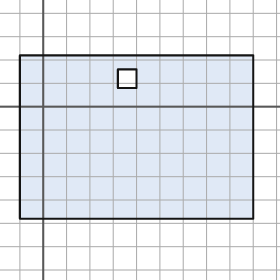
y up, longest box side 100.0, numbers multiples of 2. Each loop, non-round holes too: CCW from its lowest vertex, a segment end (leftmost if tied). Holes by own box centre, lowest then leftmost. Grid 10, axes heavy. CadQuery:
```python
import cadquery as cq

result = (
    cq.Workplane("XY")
    .moveTo(-10.0, -48.0)
    .lineTo(90.0, -48.0)
    .lineTo(90.0, 22.0)
    .lineTo(-10.0, 22.0)
    .close()
    .moveTo(32.0, 8.0)
    .lineTo(40.0, 8.0)
    .lineTo(40.0, 16.0)
    .lineTo(32.0, 16.0)
    .close()
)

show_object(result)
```